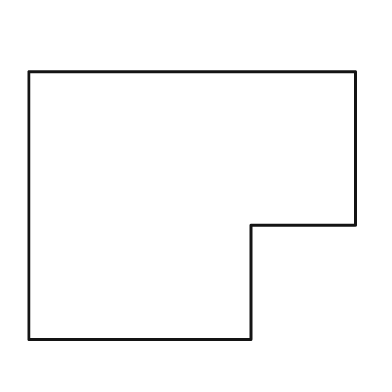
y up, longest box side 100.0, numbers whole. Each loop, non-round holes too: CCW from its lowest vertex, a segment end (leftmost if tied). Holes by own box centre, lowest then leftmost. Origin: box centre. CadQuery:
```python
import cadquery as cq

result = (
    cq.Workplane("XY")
    .moveTo(-50.0, -41.0)
    .lineTo(18.0, -41.0)
    .lineTo(18.0, -6.0)
    .lineTo(50.0, -6.0)
    .lineTo(50.0, 41.0)
    .lineTo(-50.0, 41.0)
    .close()
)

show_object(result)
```